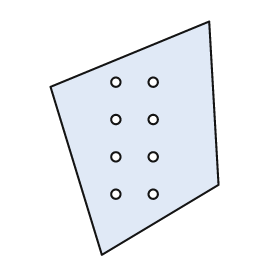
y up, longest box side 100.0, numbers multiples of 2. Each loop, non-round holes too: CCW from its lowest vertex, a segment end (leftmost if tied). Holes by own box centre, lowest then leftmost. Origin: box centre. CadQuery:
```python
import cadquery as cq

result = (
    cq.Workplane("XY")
    .moveTo(-14.0, -50.0)
    .lineTo(36.0, -20.0)
    .lineTo(32.0, 50.0)
    .lineTo(-36.0, 22.0)
    .close()
    .moveTo(-8.0, -24.0)
    .circle(2.0)
    .moveTo(8.0, -24.0)
    .circle(2.0)
    .moveTo(-8.0, -8.0)
    .circle(2.0)
    .moveTo(8.0, -8.0)
    .circle(2.0)
    .moveTo(-8.0, 8.0)
    .circle(2.0)
    .moveTo(8.0, 8.0)
    .circle(2.0)
    .moveTo(-8.0, 24.0)
    .circle(2.0)
    .moveTo(8.0, 24.0)
    .circle(2.0)
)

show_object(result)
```